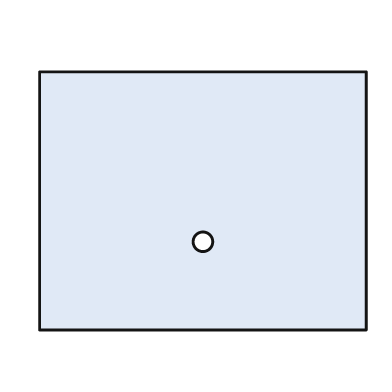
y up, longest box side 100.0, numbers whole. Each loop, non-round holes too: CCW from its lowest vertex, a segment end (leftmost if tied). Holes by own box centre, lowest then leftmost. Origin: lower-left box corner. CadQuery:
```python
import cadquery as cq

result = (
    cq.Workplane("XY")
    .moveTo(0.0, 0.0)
    .lineTo(100.0, 0.0)
    .lineTo(100.0, 79.0)
    .lineTo(0.0, 79.0)
    .close()
    .moveTo(50.0, 27.0)
    .circle(3.0)
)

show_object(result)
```